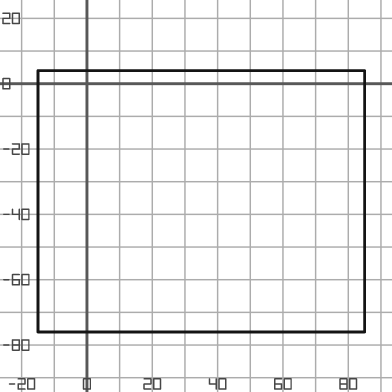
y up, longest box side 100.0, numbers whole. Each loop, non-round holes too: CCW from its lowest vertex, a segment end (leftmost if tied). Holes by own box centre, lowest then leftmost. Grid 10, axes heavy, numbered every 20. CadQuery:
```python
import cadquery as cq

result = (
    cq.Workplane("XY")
    .moveTo(-15.0, -76.0)
    .lineTo(85.0, -76.0)
    .lineTo(85.0, 4.0)
    .lineTo(-15.0, 4.0)
    .close()
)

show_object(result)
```